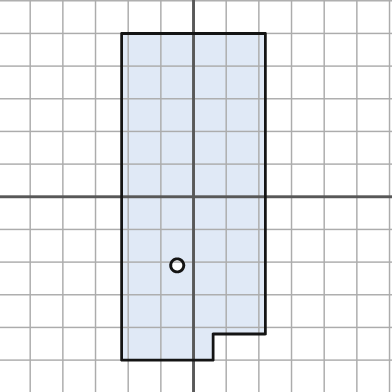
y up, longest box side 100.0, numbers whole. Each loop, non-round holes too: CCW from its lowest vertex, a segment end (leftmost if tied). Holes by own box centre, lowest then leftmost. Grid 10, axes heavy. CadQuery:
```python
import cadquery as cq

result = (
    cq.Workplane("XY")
    .moveTo(-22.0, -50.0)
    .lineTo(6.0, -50.0)
    .lineTo(6.0, -42.0)
    .lineTo(22.0, -42.0)
    .lineTo(22.0, 50.0)
    .lineTo(-22.0, 50.0)
    .close()
    .moveTo(-5.0, -21.0)
    .circle(2.0)
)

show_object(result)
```